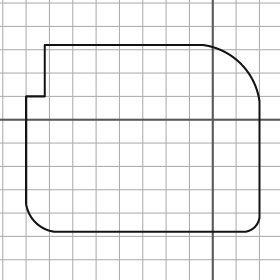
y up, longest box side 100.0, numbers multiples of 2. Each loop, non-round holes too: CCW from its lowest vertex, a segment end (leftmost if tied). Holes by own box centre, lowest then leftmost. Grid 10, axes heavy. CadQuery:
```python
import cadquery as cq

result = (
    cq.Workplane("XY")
    .moveTo(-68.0, -48.0)
    .lineTo(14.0, -48.0)
    .threePointArc((18.0, -46.0), (20.0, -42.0))
    .lineTo(20.0, 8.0)
    .threePointArc((12.0, 24.0), (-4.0, 32.0))
    .lineTo(-72.0, 32.0)
    .lineTo(-72.0, 10.0)
    .lineTo(-80.0, 10.0)
    .lineTo(-80.0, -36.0)
    .threePointArc((-76.0, -44.0), (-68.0, -48.0))
    .close()
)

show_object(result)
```